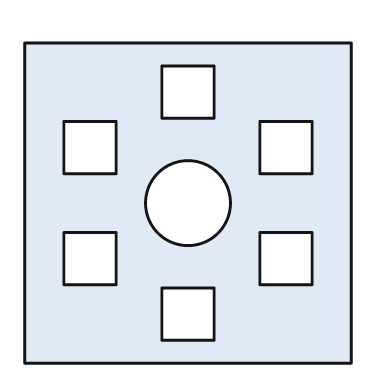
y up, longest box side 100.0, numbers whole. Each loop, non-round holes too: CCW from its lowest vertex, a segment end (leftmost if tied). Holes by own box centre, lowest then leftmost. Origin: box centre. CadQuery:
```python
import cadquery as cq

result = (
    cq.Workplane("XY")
    .moveTo(-50.0, -49.0)
    .lineTo(50.0, -49.0)
    .lineTo(50.0, 49.0)
    .lineTo(-50.0, 49.0)
    .close()
    .moveTo(-8.0, -42.0)
    .lineTo(8.0, -42.0)
    .lineTo(8.0, -26.0)
    .lineTo(-8.0, -26.0)
    .close()
    .moveTo(-38.0, -25.0)
    .lineTo(-22.0, -25.0)
    .lineTo(-22.0, -9.0)
    .lineTo(-38.0, -9.0)
    .close()
    .moveTo(22.0, -25.0)
    .lineTo(38.0, -25.0)
    .lineTo(38.0, -9.0)
    .lineTo(22.0, -9.0)
    .close()
    .moveTo(0.0, 0.0)
    .circle(13.0)
    .moveTo(-38.0, 9.0)
    .lineTo(-22.0, 9.0)
    .lineTo(-22.0, 25.0)
    .lineTo(-38.0, 25.0)
    .close()
    .moveTo(22.0, 9.0)
    .lineTo(38.0, 9.0)
    .lineTo(38.0, 25.0)
    .lineTo(22.0, 25.0)
    .close()
    .moveTo(-8.0, 26.0)
    .lineTo(8.0, 26.0)
    .lineTo(8.0, 42.0)
    .lineTo(-8.0, 42.0)
    .close()
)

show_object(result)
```